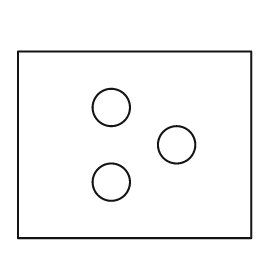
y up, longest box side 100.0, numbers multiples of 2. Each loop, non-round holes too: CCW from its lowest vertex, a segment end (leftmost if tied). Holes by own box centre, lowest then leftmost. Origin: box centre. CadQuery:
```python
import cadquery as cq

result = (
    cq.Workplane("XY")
    .moveTo(-50.0, -40.0)
    .lineTo(50.0, -40.0)
    .lineTo(50.0, 40.0)
    .lineTo(-50.0, 40.0)
    .close()
    .moveTo(-10.0, -16.0)
    .circle(8.0)
    .moveTo(18.0, 0.0)
    .circle(8.0)
    .moveTo(-10.0, 16.0)
    .circle(8.0)
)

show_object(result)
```